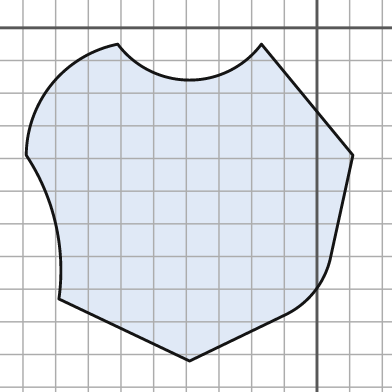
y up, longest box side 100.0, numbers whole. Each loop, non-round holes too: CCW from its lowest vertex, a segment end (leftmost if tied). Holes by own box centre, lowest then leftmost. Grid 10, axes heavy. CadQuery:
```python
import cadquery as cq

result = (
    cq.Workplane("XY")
    .moveTo(-39.0, -102.0)
    .lineTo(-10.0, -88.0)
    .threePointArc((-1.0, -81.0), (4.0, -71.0))
    .lineTo(11.0, -39.0)
    .lineTo(-17.0, -5.0)
    .threePointArc((-39.0, -16.0), (-61.0, -5.0))
    .threePointArc((-81.0, -17.0), (-89.0, -39.0))
    .threePointArc((-80.0, -60.0), (-79.0, -83.0))
    .close()
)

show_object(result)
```